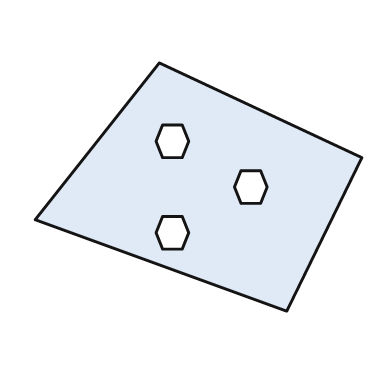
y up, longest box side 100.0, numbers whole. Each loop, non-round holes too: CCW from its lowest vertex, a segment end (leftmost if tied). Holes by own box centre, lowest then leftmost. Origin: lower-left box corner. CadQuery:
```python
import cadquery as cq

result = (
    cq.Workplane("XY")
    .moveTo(77.0, 0.0)
    .lineTo(100.0, 47.0)
    .lineTo(38.0, 76.0)
    .lineTo(0.0, 28.0)
    .close()
    .moveTo(39.0, 19.0)
    .lineTo(45.0, 19.0)
    .lineTo(47.0, 24.0)
    .lineTo(45.0, 29.0)
    .lineTo(39.0, 29.0)
    .lineTo(37.0, 24.0)
    .close()
    .moveTo(63.0, 33.0)
    .lineTo(69.0, 33.0)
    .lineTo(71.0, 38.0)
    .lineTo(69.0, 43.0)
    .lineTo(63.0, 43.0)
    .lineTo(61.0, 38.0)
    .close()
    .moveTo(39.0, 47.0)
    .lineTo(45.0, 47.0)
    .lineTo(47.0, 52.0)
    .lineTo(45.0, 57.0)
    .lineTo(39.0, 57.0)
    .lineTo(37.0, 52.0)
    .close()
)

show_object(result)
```